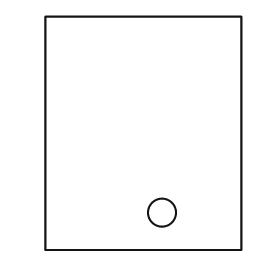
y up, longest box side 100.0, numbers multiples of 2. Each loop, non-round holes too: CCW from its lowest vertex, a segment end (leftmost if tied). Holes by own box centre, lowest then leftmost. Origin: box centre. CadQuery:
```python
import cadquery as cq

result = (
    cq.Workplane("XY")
    .moveTo(-42.0, -50.0)
    .lineTo(42.0, -50.0)
    .lineTo(42.0, 50.0)
    .lineTo(-42.0, 50.0)
    .close()
    .moveTo(8.0, -34.0)
    .circle(6.0)
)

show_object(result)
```